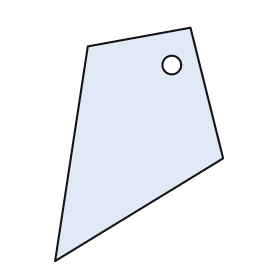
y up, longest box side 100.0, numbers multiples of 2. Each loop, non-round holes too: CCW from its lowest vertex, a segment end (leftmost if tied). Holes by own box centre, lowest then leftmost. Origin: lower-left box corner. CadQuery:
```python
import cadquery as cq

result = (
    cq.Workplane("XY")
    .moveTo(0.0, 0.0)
    .lineTo(72.0, 44.0)
    .lineTo(58.0, 100.0)
    .lineTo(14.0, 92.0)
    .close()
    .moveTo(50.0, 84.0)
    .circle(4.0)
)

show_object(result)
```